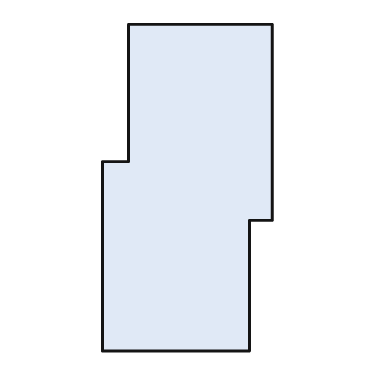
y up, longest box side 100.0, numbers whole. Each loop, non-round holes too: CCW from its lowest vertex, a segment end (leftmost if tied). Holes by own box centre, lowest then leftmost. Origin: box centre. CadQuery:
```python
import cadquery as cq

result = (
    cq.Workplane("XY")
    .moveTo(-26.0, -50.0)
    .lineTo(19.0, -50.0)
    .lineTo(19.0, -10.0)
    .lineTo(26.0, -10.0)
    .lineTo(26.0, 50.0)
    .lineTo(-18.0, 50.0)
    .lineTo(-18.0, 8.0)
    .lineTo(-26.0, 8.0)
    .close()
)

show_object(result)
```